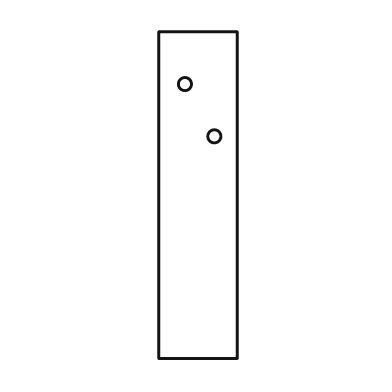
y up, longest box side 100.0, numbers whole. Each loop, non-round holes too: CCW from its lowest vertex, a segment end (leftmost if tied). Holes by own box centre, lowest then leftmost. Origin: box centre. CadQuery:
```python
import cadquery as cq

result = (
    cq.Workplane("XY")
    .moveTo(-12.0, -50.0)
    .lineTo(12.0, -50.0)
    .lineTo(12.0, 50.0)
    .lineTo(-12.0, 50.0)
    .close()
    .moveTo(5.0, 18.0)
    .circle(2.0)
    .moveTo(-4.0, 34.0)
    .circle(2.0)
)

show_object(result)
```